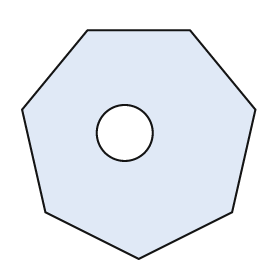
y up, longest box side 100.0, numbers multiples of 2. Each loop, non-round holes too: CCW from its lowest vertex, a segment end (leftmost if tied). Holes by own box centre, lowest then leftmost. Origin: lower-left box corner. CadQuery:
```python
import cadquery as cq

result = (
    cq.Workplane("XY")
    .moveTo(50.0, 0.0)
    .lineTo(90.0, 20.0)
    .lineTo(100.0, 64.0)
    .lineTo(72.0, 98.0)
    .lineTo(28.0, 98.0)
    .lineTo(0.0, 64.0)
    .lineTo(10.0, 20.0)
    .close()
    .moveTo(44.0, 54.0)
    .circle(12.0)
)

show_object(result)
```